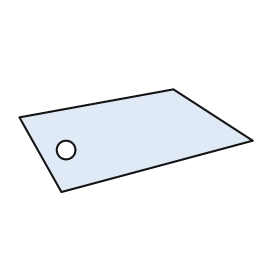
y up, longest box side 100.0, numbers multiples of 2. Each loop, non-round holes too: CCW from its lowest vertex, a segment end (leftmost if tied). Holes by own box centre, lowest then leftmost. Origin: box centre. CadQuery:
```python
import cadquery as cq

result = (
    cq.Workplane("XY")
    .moveTo(-32.0, -22.0)
    .lineTo(50.0, 0.0)
    .lineTo(16.0, 22.0)
    .lineTo(-50.0, 10.0)
    .close()
    .moveTo(-30.0, -4.0)
    .circle(4.0)
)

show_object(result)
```